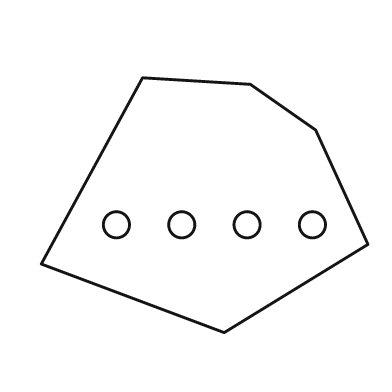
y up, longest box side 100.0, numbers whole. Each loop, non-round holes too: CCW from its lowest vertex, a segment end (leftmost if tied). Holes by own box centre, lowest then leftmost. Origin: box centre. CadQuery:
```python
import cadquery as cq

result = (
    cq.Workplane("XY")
    .moveTo(6.0, -39.0)
    .lineTo(50.0, -12.0)
    .lineTo(34.0, 23.0)
    .lineTo(14.0, 37.0)
    .lineTo(-19.0, 39.0)
    .lineTo(-50.0, -18.0)
    .close()
    .moveTo(-27.0, -6.0)
    .circle(4.0)
    .moveTo(-7.0, -6.0)
    .circle(4.0)
    .moveTo(13.0, -6.0)
    .circle(4.0)
    .moveTo(33.0, -6.0)
    .circle(4.0)
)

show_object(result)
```